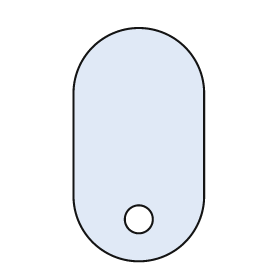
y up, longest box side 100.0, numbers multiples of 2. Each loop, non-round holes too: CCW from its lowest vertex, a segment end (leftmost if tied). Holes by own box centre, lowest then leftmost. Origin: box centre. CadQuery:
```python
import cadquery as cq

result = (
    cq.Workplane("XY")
    .moveTo(-28.0, -22.0)
    .threePointArc((0.0, -50.0), (28.0, -22.0))
    .lineTo(28.0, 22.0)
    .threePointArc((0.0, 50.0), (-28.0, 22.0))
    .close()
    .moveTo(0.0, -32.0)
    .circle(6.0)
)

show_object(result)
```